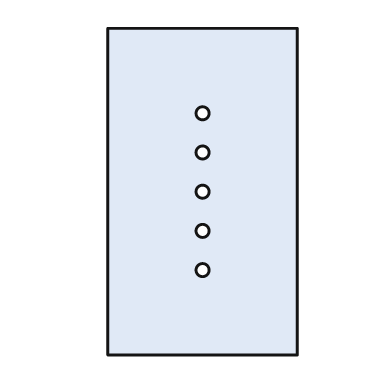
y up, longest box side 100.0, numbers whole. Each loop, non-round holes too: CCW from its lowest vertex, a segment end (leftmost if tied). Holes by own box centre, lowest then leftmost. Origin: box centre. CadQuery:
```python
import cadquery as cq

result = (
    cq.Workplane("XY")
    .moveTo(-29.0, -50.0)
    .lineTo(29.0, -50.0)
    .lineTo(29.0, 50.0)
    .lineTo(-29.0, 50.0)
    .close()
    .moveTo(0.0, -24.0)
    .circle(2.0)
    .moveTo(0.0, -12.0)
    .circle(2.0)
    .moveTo(0.0, 0.0)
    .circle(2.0)
    .moveTo(0.0, 12.0)
    .circle(2.0)
    .moveTo(0.0, 24.0)
    .circle(2.0)
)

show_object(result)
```